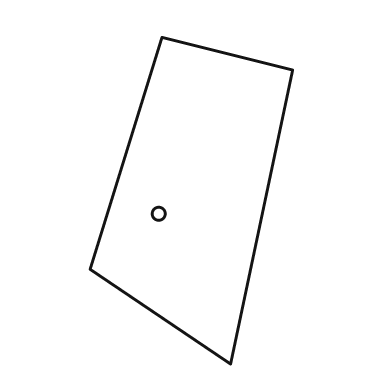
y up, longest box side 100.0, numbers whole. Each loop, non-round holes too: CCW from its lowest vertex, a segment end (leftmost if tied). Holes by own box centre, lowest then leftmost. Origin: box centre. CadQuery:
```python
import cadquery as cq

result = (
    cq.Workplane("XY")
    .moveTo(12.0, -50.0)
    .lineTo(31.0, 40.0)
    .lineTo(-9.0, 50.0)
    .lineTo(-31.0, -21.0)
    .close()
    .moveTo(-10.0, -4.0)
    .circle(2.0)
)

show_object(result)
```